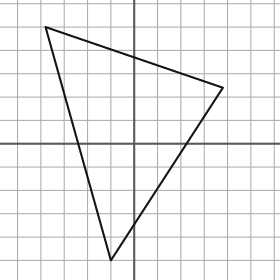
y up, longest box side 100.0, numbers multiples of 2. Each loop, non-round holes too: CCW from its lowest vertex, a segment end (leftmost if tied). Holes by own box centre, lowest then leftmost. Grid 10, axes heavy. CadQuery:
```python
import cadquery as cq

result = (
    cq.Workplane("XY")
    .moveTo(-10.0, -50.0)
    .lineTo(38.0, 24.0)
    .lineTo(-38.0, 50.0)
    .close()
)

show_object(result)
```